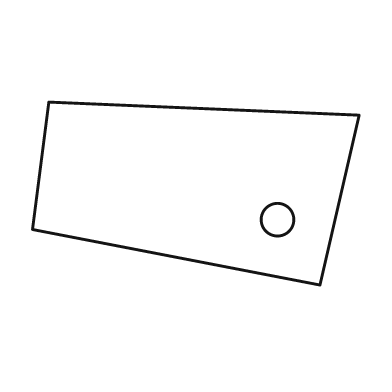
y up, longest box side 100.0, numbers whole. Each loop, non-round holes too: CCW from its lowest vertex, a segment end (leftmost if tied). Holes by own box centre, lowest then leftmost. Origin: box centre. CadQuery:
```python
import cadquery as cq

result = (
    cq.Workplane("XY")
    .moveTo(38.0, -28.0)
    .lineTo(50.0, 24.0)
    .lineTo(-45.0, 28.0)
    .lineTo(-50.0, -11.0)
    .close()
    .moveTo(25.0, -8.0)
    .circle(5.0)
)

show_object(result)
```